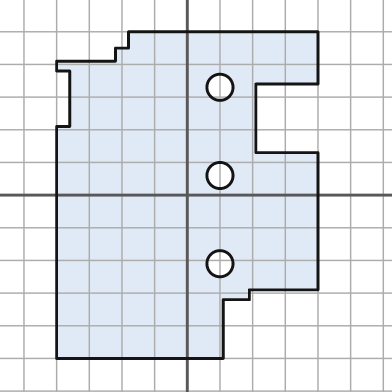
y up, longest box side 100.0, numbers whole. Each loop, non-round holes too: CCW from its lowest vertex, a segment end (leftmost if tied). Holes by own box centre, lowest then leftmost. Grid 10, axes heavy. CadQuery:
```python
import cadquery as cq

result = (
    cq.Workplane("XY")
    .moveTo(-40.0, -50.0)
    .lineTo(11.0, -50.0)
    .lineTo(11.0, -32.0)
    .lineTo(19.0, -32.0)
    .lineTo(19.0, -29.0)
    .lineTo(40.0, -29.0)
    .lineTo(40.0, 13.0)
    .lineTo(21.0, 13.0)
    .lineTo(21.0, 34.0)
    .lineTo(40.0, 34.0)
    .lineTo(40.0, 50.0)
    .lineTo(-18.0, 50.0)
    .lineTo(-18.0, 45.0)
    .lineTo(-22.0, 45.0)
    .lineTo(-22.0, 41.0)
    .lineTo(-40.0, 41.0)
    .lineTo(-40.0, 38.0)
    .lineTo(-36.0, 38.0)
    .lineTo(-36.0, 21.0)
    .lineTo(-40.0, 21.0)
    .close()
    .moveTo(10.0, -21.0)
    .circle(4.0)
    .moveTo(10.0, 6.0)
    .circle(4.0)
    .moveTo(10.0, 33.0)
    .circle(4.0)
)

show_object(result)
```